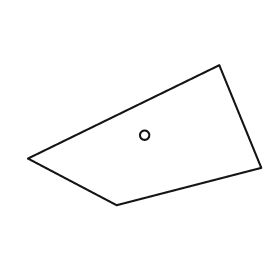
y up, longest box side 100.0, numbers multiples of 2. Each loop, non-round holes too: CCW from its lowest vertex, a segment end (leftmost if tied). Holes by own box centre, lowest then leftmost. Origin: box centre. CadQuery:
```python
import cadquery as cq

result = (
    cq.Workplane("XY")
    .moveTo(-12.0, -30.0)
    .lineTo(50.0, -14.0)
    .lineTo(32.0, 30.0)
    .lineTo(-50.0, -10.0)
    .close()
    .moveTo(0.0, 0.0)
    .circle(2.0)
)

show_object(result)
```